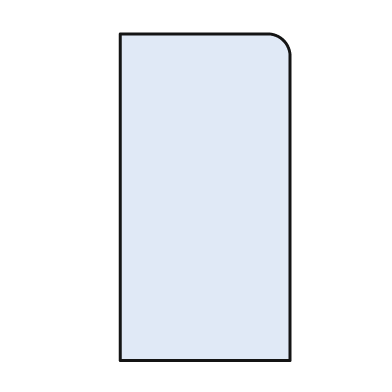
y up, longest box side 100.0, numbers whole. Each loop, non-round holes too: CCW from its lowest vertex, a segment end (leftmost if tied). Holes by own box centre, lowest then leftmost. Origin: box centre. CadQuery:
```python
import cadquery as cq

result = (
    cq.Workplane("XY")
    .moveTo(-26.0, -50.0)
    .lineTo(26.0, -50.0)
    .lineTo(26.0, 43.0)
    .threePointArc((24.0, 48.0), (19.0, 50.0))
    .lineTo(-26.0, 50.0)
    .close()
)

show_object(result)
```